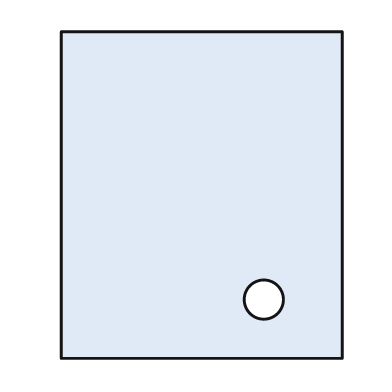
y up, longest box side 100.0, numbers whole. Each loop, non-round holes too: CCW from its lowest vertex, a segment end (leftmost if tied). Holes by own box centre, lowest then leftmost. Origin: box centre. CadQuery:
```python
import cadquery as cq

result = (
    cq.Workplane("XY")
    .moveTo(-43.0, -50.0)
    .lineTo(43.0, -50.0)
    .lineTo(43.0, 50.0)
    .lineTo(-43.0, 50.0)
    .close()
    .moveTo(19.0, -32.0)
    .circle(6.0)
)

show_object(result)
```